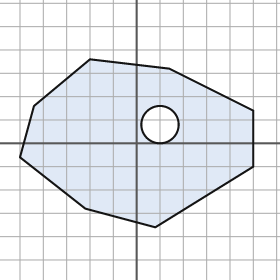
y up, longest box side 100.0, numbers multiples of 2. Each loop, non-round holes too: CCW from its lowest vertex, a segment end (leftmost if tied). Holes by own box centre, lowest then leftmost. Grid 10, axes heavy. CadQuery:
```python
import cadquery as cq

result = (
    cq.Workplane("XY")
    .moveTo(8.0, -36.0)
    .lineTo(50.0, -10.0)
    .lineTo(50.0, 14.0)
    .lineTo(14.0, 32.0)
    .lineTo(-20.0, 36.0)
    .lineTo(-44.0, 16.0)
    .lineTo(-50.0, -6.0)
    .lineTo(-22.0, -28.0)
    .close()
    .moveTo(10.0, 8.0)
    .circle(8.0)
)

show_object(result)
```